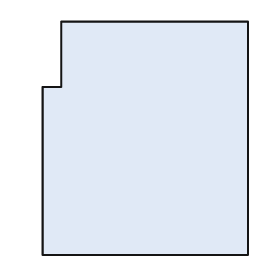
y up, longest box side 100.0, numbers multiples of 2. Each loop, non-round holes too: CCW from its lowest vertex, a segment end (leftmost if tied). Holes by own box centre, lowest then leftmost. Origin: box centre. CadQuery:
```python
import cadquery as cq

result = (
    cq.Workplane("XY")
    .moveTo(-44.0, -50.0)
    .lineTo(44.0, -50.0)
    .lineTo(44.0, 50.0)
    .lineTo(-36.0, 50.0)
    .lineTo(-36.0, 22.0)
    .lineTo(-44.0, 22.0)
    .close()
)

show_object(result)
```